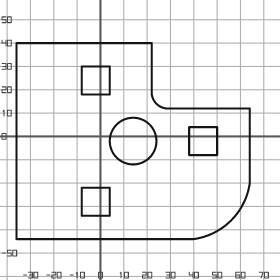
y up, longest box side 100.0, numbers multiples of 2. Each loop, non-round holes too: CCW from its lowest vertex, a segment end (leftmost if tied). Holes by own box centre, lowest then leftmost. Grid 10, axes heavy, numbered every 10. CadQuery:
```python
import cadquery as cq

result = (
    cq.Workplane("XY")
    .moveTo(-36.0, -44.0)
    .lineTo(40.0, -44.0)
    .threePointArc((56.0, -36.0), (64.0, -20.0))
    .lineTo(64.0, 12.0)
    .lineTo(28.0, 12.0)
    .threePointArc((24.0, 14.0), (22.0, 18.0))
    .lineTo(22.0, 40.0)
    .lineTo(-36.0, 40.0)
    .close()
    .moveTo(-8.0, -34.0)
    .lineTo(4.0, -34.0)
    .lineTo(4.0, -22.0)
    .lineTo(-8.0, -22.0)
    .close()
    .moveTo(14.0, -2.0)
    .circle(10.0)
    .moveTo(38.0, -8.0)
    .lineTo(50.0, -8.0)
    .lineTo(50.0, 4.0)
    .lineTo(38.0, 4.0)
    .close()
    .moveTo(-8.0, 18.0)
    .lineTo(4.0, 18.0)
    .lineTo(4.0, 30.0)
    .lineTo(-8.0, 30.0)
    .close()
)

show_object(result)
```